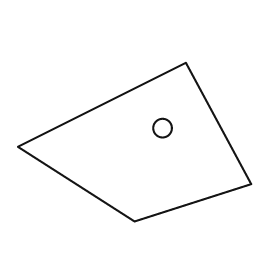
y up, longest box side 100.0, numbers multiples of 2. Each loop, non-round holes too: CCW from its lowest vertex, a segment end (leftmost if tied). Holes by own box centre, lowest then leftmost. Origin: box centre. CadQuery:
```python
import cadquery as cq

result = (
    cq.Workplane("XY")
    .moveTo(0.0, -34.0)
    .lineTo(50.0, -18.0)
    .lineTo(22.0, 34.0)
    .lineTo(-50.0, -2.0)
    .close()
    .moveTo(12.0, 6.0)
    .circle(4.0)
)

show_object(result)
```